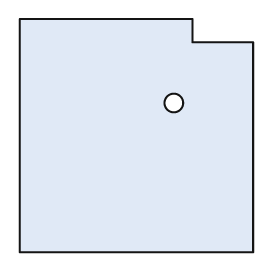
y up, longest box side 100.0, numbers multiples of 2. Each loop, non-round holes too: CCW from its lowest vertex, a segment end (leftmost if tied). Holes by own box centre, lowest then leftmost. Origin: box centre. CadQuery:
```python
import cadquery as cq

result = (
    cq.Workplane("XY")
    .moveTo(-50.0, -50.0)
    .lineTo(50.0, -50.0)
    .lineTo(50.0, 40.0)
    .lineTo(24.0, 40.0)
    .lineTo(24.0, 50.0)
    .lineTo(-50.0, 50.0)
    .close()
    .moveTo(16.0, 14.0)
    .circle(4.0)
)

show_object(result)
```